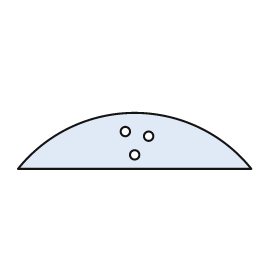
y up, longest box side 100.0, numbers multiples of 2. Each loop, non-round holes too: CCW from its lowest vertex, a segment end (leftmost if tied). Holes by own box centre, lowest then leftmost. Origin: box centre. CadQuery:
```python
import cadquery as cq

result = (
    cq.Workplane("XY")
    .moveTo(-50.0, -12.0)
    .lineTo(50.0, -12.0)
    .threePointArc((0.0, 12.0), (-50.0, -12.0))
    .close()
    .moveTo(0.0, -6.0)
    .circle(2.0)
    .moveTo(6.0, 2.0)
    .circle(2.0)
    .moveTo(-4.0, 4.0)
    .circle(2.0)
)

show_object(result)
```